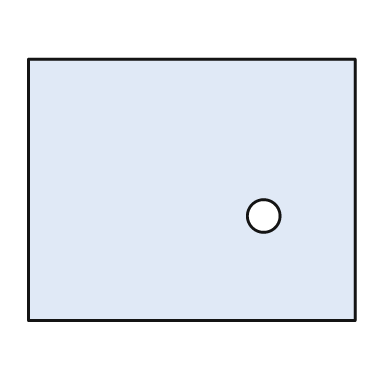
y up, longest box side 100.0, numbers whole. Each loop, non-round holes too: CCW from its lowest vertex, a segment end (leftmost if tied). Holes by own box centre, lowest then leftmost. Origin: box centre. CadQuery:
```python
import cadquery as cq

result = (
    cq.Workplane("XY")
    .moveTo(-50.0, -40.0)
    .lineTo(50.0, -40.0)
    .lineTo(50.0, 40.0)
    .lineTo(-50.0, 40.0)
    .close()
    .moveTo(22.0, -8.0)
    .circle(5.0)
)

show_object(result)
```